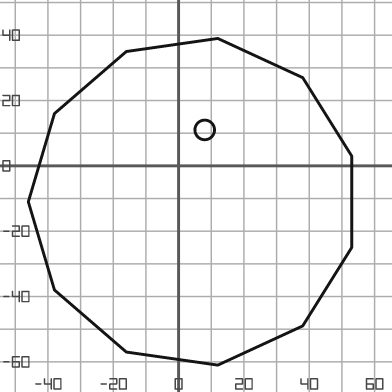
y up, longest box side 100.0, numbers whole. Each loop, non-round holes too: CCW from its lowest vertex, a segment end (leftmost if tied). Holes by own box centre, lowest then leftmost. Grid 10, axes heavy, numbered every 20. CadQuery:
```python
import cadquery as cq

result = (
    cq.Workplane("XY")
    .moveTo(12.0, -61.0)
    .lineTo(38.0, -49.0)
    .lineTo(53.0, -25.0)
    .lineTo(53.0, 3.0)
    .lineTo(38.0, 27.0)
    .lineTo(12.0, 39.0)
    .lineTo(-16.0, 35.0)
    .lineTo(-38.0, 16.0)
    .lineTo(-46.0, -11.0)
    .lineTo(-38.0, -38.0)
    .lineTo(-16.0, -57.0)
    .close()
    .moveTo(8.0, 11.0)
    .circle(3.0)
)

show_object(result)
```